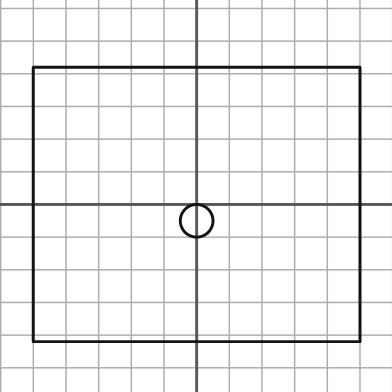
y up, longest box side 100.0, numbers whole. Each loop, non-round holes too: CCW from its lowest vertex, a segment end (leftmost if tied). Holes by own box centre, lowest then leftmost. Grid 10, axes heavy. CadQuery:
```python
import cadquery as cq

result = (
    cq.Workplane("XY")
    .moveTo(-50.0, -42.0)
    .lineTo(50.0, -42.0)
    .lineTo(50.0, 42.0)
    .lineTo(-50.0, 42.0)
    .close()
    .moveTo(0.0, -5.0)
    .circle(5.0)
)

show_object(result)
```